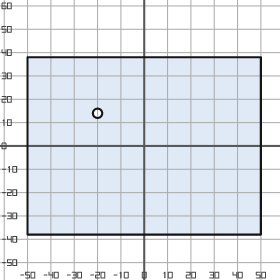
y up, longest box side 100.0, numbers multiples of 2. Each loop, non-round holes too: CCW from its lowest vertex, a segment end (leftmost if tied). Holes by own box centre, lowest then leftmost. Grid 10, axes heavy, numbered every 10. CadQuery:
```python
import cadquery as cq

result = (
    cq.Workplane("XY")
    .moveTo(-50.0, -38.0)
    .lineTo(50.0, -38.0)
    .lineTo(50.0, 38.0)
    .lineTo(-50.0, 38.0)
    .close()
    .moveTo(-20.0, 14.0)
    .circle(2.0)
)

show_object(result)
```